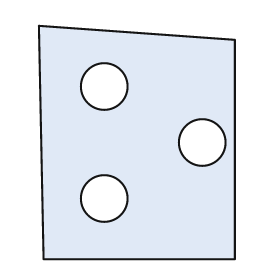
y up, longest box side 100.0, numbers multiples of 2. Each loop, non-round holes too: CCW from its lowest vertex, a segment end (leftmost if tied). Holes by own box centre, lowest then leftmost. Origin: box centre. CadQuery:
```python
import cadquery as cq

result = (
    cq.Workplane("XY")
    .moveTo(-40.0, -50.0)
    .lineTo(42.0, -50.0)
    .lineTo(42.0, 44.0)
    .lineTo(-42.0, 50.0)
    .close()
    .moveTo(-14.0, -24.0)
    .circle(10.0)
    .moveTo(28.0, 0.0)
    .circle(10.0)
    .moveTo(-14.0, 24.0)
    .circle(10.0)
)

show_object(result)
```